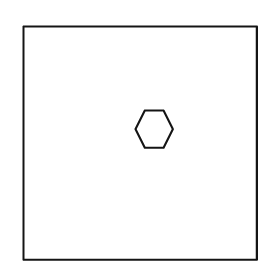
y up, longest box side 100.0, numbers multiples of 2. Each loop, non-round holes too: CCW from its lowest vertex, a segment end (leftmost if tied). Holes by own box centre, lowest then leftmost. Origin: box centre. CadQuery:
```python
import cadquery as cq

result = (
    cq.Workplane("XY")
    .moveTo(-50.0, -50.0)
    .lineTo(50.0, -50.0)
    .lineTo(50.0, 50.0)
    .lineTo(-50.0, 50.0)
    .close()
    .moveTo(2.0, -2.0)
    .lineTo(10.0, -2.0)
    .lineTo(14.0, 6.0)
    .lineTo(10.0, 14.0)
    .lineTo(2.0, 14.0)
    .lineTo(-2.0, 6.0)
    .close()
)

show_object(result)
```